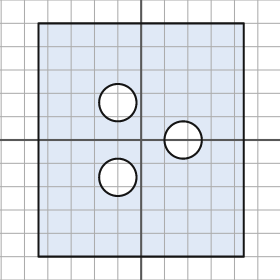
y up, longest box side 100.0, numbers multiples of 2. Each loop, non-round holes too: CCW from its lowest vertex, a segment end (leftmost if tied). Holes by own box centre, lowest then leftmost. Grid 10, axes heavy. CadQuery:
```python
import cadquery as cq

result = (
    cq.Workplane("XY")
    .moveTo(-44.0, -50.0)
    .lineTo(44.0, -50.0)
    .lineTo(44.0, 50.0)
    .lineTo(-44.0, 50.0)
    .close()
    .moveTo(-10.0, -16.0)
    .circle(8.0)
    .moveTo(18.0, 0.0)
    .circle(8.0)
    .moveTo(-10.0, 16.0)
    .circle(8.0)
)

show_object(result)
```